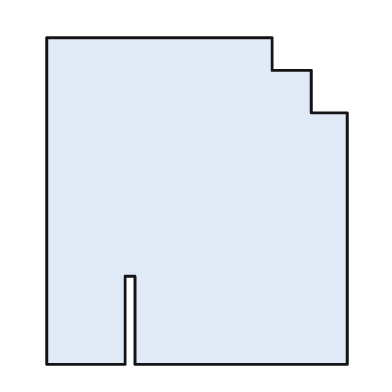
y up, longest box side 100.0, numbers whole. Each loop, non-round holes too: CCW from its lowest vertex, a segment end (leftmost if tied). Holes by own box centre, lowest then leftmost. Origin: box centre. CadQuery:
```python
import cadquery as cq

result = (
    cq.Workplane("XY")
    .moveTo(-46.0, -50.0)
    .lineTo(-22.0, -50.0)
    .lineTo(-22.0, -23.0)
    .lineTo(-19.0, -23.0)
    .lineTo(-19.0, -50.0)
    .lineTo(46.0, -50.0)
    .lineTo(46.0, 27.0)
    .lineTo(35.0, 27.0)
    .lineTo(35.0, 40.0)
    .lineTo(23.0, 40.0)
    .lineTo(23.0, 50.0)
    .lineTo(-46.0, 50.0)
    .close()
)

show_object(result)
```